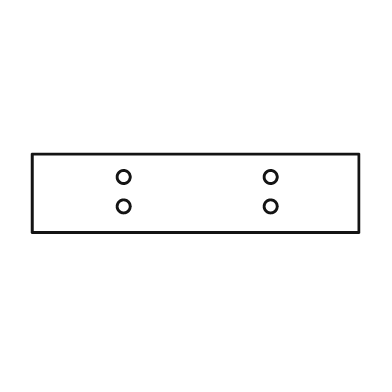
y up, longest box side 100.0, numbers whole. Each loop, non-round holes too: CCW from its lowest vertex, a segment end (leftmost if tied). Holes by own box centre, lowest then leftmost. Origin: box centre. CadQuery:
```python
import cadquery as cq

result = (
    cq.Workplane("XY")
    .moveTo(-50.0, -12.0)
    .lineTo(50.0, -12.0)
    .lineTo(50.0, 12.0)
    .lineTo(-50.0, 12.0)
    .close()
    .moveTo(-22.0, -4.0)
    .circle(2.0)
    .moveTo(23.0, -4.0)
    .circle(2.0)
    .moveTo(-22.0, 5.0)
    .circle(2.0)
    .moveTo(23.0, 5.0)
    .circle(2.0)
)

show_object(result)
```